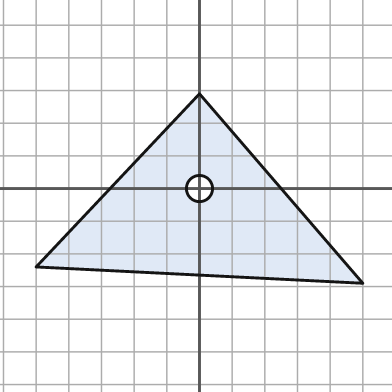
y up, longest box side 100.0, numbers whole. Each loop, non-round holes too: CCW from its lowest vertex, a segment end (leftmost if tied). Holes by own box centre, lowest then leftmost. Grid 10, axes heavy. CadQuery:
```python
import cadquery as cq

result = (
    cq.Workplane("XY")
    .moveTo(50.0, -29.0)
    .lineTo(0.0, 29.0)
    .lineTo(-50.0, -24.0)
    .close()
    .moveTo(0.0, 0.0)
    .circle(4.0)
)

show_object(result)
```